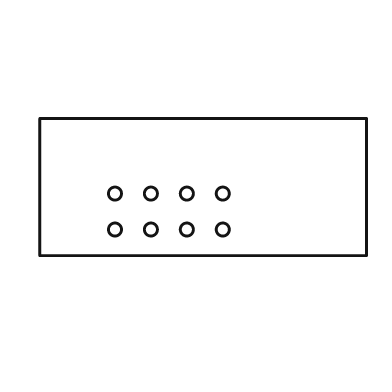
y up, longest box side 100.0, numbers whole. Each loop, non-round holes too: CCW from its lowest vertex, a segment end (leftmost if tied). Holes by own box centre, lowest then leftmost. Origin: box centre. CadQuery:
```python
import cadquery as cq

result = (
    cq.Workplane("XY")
    .moveTo(-50.0, -21.0)
    .lineTo(50.0, -21.0)
    .lineTo(50.0, 21.0)
    .lineTo(-50.0, 21.0)
    .close()
    .moveTo(-27.0, -13.0)
    .circle(2.0)
    .moveTo(-16.0, -13.0)
    .circle(2.0)
    .moveTo(-5.0, -13.0)
    .circle(2.0)
    .moveTo(6.0, -13.0)
    .circle(2.0)
    .moveTo(-27.0, -2.0)
    .circle(2.0)
    .moveTo(-16.0, -2.0)
    .circle(2.0)
    .moveTo(-5.0, -2.0)
    .circle(2.0)
    .moveTo(6.0, -2.0)
    .circle(2.0)
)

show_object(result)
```